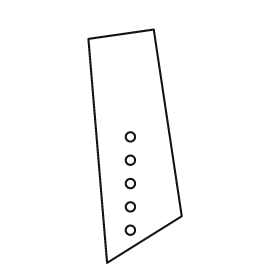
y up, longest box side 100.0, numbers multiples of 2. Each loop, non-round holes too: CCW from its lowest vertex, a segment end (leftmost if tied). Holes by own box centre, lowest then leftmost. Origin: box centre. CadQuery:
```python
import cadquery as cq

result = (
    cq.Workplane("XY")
    .moveTo(-12.0, -50.0)
    .lineTo(20.0, -30.0)
    .lineTo(8.0, 50.0)
    .lineTo(-20.0, 46.0)
    .close()
    .moveTo(-2.0, -36.0)
    .circle(2.0)
    .moveTo(-2.0, -26.0)
    .circle(2.0)
    .moveTo(-2.0, -16.0)
    .circle(2.0)
    .moveTo(-2.0, -6.0)
    .circle(2.0)
    .moveTo(-2.0, 4.0)
    .circle(2.0)
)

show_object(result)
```